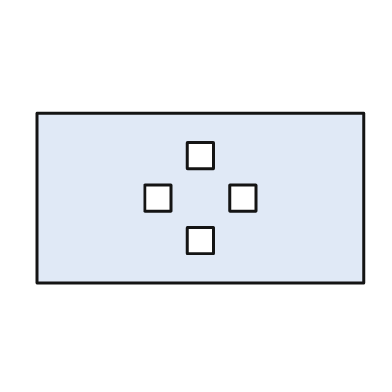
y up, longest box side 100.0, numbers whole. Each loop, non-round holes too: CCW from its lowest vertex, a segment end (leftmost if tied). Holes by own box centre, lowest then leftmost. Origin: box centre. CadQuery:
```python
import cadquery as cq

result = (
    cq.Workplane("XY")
    .moveTo(-50.0, -26.0)
    .lineTo(50.0, -26.0)
    .lineTo(50.0, 26.0)
    .lineTo(-50.0, 26.0)
    .close()
    .moveTo(-4.0, -17.0)
    .lineTo(4.0, -17.0)
    .lineTo(4.0, -9.0)
    .lineTo(-4.0, -9.0)
    .close()
    .moveTo(-17.0, -4.0)
    .lineTo(-9.0, -4.0)
    .lineTo(-9.0, 4.0)
    .lineTo(-17.0, 4.0)
    .close()
    .moveTo(9.0, -4.0)
    .lineTo(17.0, -4.0)
    .lineTo(17.0, 4.0)
    .lineTo(9.0, 4.0)
    .close()
    .moveTo(-4.0, 9.0)
    .lineTo(4.0, 9.0)
    .lineTo(4.0, 17.0)
    .lineTo(-4.0, 17.0)
    .close()
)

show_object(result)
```